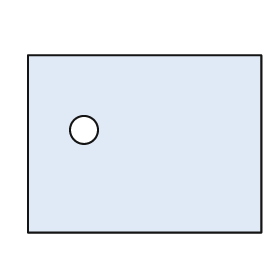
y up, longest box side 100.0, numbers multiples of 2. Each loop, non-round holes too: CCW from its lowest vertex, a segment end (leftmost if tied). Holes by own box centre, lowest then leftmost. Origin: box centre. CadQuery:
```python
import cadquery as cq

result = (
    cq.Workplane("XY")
    .moveTo(-50.0, -38.0)
    .lineTo(50.0, -38.0)
    .lineTo(50.0, 38.0)
    .lineTo(-50.0, 38.0)
    .close()
    .moveTo(-26.0, 6.0)
    .circle(6.0)
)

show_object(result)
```